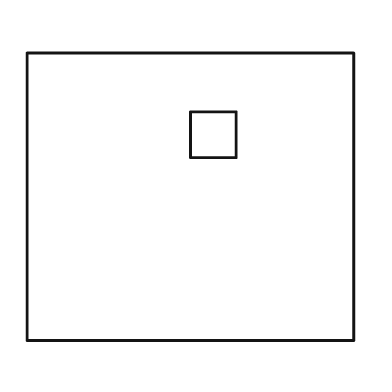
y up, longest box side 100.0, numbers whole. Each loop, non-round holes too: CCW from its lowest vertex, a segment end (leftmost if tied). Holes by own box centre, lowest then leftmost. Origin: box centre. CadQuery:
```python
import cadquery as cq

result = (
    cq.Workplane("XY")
    .moveTo(-50.0, -44.0)
    .lineTo(50.0, -44.0)
    .lineTo(50.0, 44.0)
    .lineTo(-50.0, 44.0)
    .close()
    .moveTo(0.0, 12.0)
    .lineTo(14.0, 12.0)
    .lineTo(14.0, 26.0)
    .lineTo(0.0, 26.0)
    .close()
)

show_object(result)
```